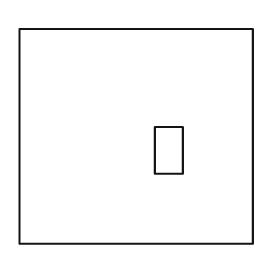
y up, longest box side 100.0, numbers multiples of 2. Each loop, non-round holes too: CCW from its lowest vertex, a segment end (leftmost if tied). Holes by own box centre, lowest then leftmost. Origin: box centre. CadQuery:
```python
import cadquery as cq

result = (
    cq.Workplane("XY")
    .moveTo(-50.0, -46.0)
    .lineTo(50.0, -46.0)
    .lineTo(50.0, 46.0)
    .lineTo(-50.0, 46.0)
    .close()
    .moveTo(8.0, -16.0)
    .lineTo(20.0, -16.0)
    .lineTo(20.0, 4.0)
    .lineTo(8.0, 4.0)
    .close()
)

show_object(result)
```